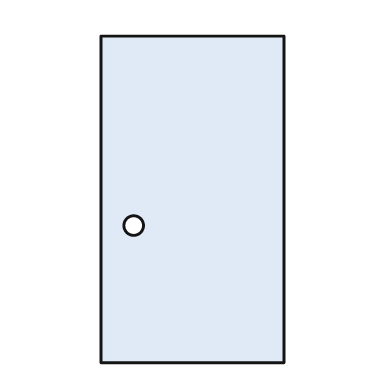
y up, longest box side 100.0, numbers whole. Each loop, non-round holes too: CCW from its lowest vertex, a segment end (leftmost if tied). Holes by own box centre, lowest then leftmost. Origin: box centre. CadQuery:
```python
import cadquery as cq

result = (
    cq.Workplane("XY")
    .moveTo(-28.0, -50.0)
    .lineTo(28.0, -50.0)
    .lineTo(28.0, 50.0)
    .lineTo(-28.0, 50.0)
    .close()
    .moveTo(-18.0, -8.0)
    .circle(3.0)
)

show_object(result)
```